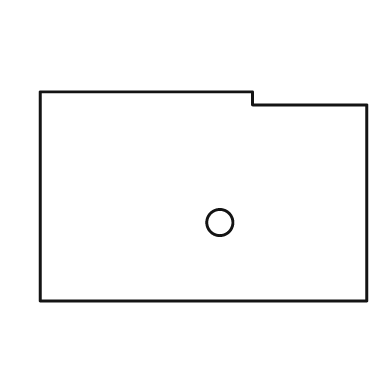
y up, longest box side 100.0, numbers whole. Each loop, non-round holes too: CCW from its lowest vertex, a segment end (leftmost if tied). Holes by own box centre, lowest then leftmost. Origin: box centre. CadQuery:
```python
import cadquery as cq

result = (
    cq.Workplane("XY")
    .moveTo(-50.0, -32.0)
    .lineTo(50.0, -32.0)
    .lineTo(50.0, 28.0)
    .lineTo(15.0, 28.0)
    .lineTo(15.0, 32.0)
    .lineTo(-50.0, 32.0)
    .close()
    .moveTo(5.0, -8.0)
    .circle(4.0)
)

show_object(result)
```